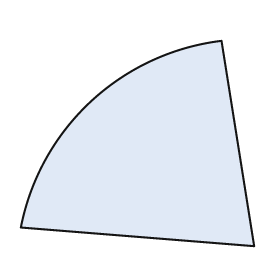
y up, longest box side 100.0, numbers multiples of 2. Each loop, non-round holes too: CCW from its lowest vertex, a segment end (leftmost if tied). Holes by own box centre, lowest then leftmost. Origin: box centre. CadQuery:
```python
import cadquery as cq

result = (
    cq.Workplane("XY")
    .moveTo(50.0, -44.0)
    .lineTo(36.0, 44.0)
    .threePointArc((-20.0, 18.0), (-50.0, -36.0))
    .close()
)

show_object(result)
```